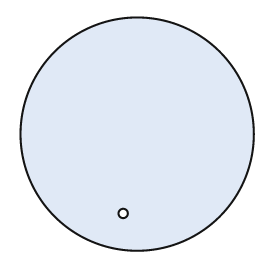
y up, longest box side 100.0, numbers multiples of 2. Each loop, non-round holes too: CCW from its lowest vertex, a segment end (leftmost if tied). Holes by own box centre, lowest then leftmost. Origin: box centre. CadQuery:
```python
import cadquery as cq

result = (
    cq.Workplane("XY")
    .moveTo(0.0, 0.0)
    .circle(50.0)
    .moveTo(-6.0, -34.0)
    .circle(2.0)
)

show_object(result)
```